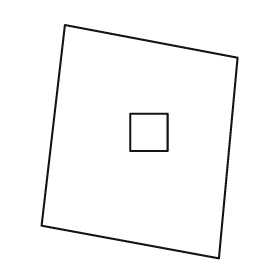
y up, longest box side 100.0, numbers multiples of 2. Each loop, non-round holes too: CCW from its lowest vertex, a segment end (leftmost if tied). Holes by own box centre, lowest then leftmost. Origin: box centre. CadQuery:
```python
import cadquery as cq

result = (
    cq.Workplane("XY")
    .moveTo(34.0, -50.0)
    .lineTo(42.0, 36.0)
    .lineTo(-32.0, 50.0)
    .lineTo(-42.0, -36.0)
    .close()
    .moveTo(-4.0, -4.0)
    .lineTo(12.0, -4.0)
    .lineTo(12.0, 12.0)
    .lineTo(-4.0, 12.0)
    .close()
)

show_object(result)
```